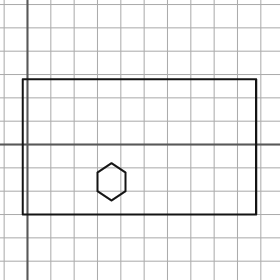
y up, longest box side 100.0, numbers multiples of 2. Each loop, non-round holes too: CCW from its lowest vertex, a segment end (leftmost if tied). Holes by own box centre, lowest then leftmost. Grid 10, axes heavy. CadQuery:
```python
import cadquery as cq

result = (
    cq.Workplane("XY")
    .moveTo(-2.0, -30.0)
    .lineTo(98.0, -30.0)
    .lineTo(98.0, 28.0)
    .lineTo(-2.0, 28.0)
    .close()
    .moveTo(36.0, -24.0)
    .lineTo(42.0, -20.0)
    .lineTo(42.0, -12.0)
    .lineTo(36.0, -8.0)
    .lineTo(30.0, -12.0)
    .lineTo(30.0, -20.0)
    .close()
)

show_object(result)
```